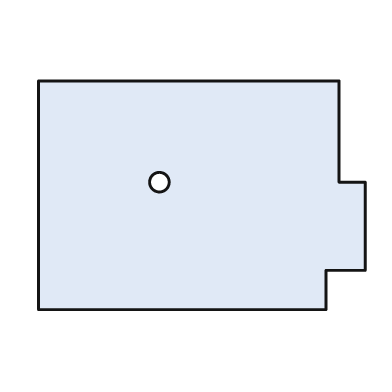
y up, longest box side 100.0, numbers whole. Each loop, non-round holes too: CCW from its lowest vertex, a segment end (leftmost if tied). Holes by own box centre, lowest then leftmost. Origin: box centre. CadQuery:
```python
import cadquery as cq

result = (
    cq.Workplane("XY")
    .moveTo(-50.0, -35.0)
    .lineTo(38.0, -35.0)
    .lineTo(38.0, -23.0)
    .lineTo(50.0, -23.0)
    .lineTo(50.0, 4.0)
    .lineTo(42.0, 4.0)
    .lineTo(42.0, 35.0)
    .lineTo(-50.0, 35.0)
    .close()
    .moveTo(-13.0, 4.0)
    .circle(3.0)
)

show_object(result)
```